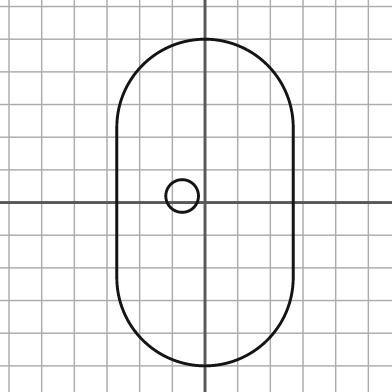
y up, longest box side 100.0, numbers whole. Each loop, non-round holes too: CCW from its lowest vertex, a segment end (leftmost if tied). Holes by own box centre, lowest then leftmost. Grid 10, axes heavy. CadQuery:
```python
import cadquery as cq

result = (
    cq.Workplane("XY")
    .moveTo(-27.0, -23.0)
    .threePointArc((0.0, -50.0), (27.0, -23.0))
    .lineTo(27.0, 23.0)
    .threePointArc((0.0, 50.0), (-27.0, 23.0))
    .close()
    .moveTo(-7.0, 2.0)
    .circle(5.0)
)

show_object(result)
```